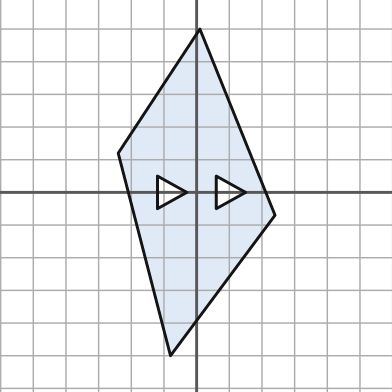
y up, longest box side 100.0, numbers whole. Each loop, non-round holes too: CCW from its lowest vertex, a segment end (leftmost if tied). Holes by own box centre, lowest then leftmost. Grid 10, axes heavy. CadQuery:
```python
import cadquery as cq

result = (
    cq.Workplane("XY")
    .moveTo(-8.0, -50.0)
    .lineTo(24.0, -7.0)
    .lineTo(1.0, 50.0)
    .lineTo(-24.0, 12.0)
    .close()
    .moveTo(-12.0, -5.0)
    .lineTo(-3.0, 0.0)
    .lineTo(-12.0, 5.0)
    .close()
    .moveTo(6.0, -5.0)
    .lineTo(15.0, 0.0)
    .lineTo(6.0, 5.0)
    .close()
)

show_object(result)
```